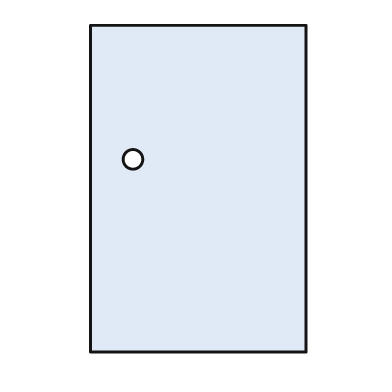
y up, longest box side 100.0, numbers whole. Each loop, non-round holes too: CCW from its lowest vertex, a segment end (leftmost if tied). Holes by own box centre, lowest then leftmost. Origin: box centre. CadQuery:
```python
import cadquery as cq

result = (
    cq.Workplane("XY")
    .moveTo(-33.0, -50.0)
    .lineTo(33.0, -50.0)
    .lineTo(33.0, 50.0)
    .lineTo(-33.0, 50.0)
    .close()
    .moveTo(-20.0, 9.0)
    .circle(3.0)
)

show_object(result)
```